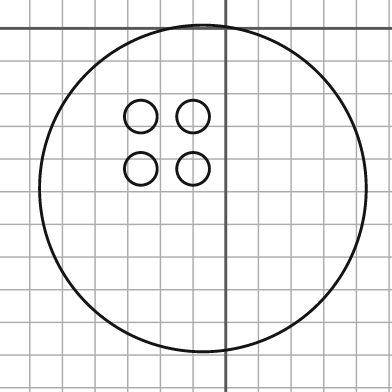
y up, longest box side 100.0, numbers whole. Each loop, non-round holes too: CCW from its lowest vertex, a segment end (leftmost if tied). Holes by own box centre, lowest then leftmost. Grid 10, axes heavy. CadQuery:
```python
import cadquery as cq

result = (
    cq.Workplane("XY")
    .moveTo(-7.0, -49.0)
    .circle(50.0)
    .moveTo(-26.0, -43.0)
    .circle(5.0)
    .moveTo(-10.0, -43.0)
    .circle(5.0)
    .moveTo(-26.0, -27.0)
    .circle(5.0)
    .moveTo(-10.0, -27.0)
    .circle(5.0)
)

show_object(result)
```